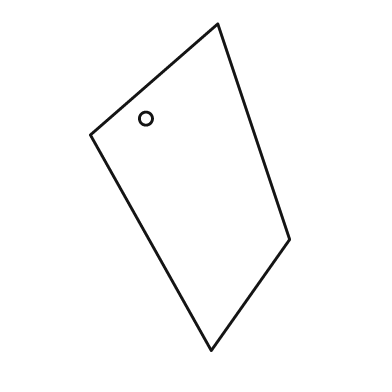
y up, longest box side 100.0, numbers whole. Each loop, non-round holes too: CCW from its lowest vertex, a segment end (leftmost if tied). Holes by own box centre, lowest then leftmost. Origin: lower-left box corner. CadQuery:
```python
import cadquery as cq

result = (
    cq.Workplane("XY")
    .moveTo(37.0, 0.0)
    .lineTo(61.0, 34.0)
    .lineTo(39.0, 100.0)
    .lineTo(0.0, 66.0)
    .close()
    .moveTo(17.0, 71.0)
    .circle(2.0)
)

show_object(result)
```